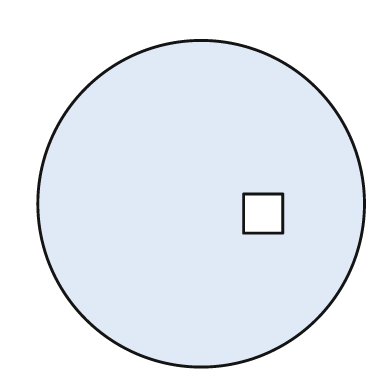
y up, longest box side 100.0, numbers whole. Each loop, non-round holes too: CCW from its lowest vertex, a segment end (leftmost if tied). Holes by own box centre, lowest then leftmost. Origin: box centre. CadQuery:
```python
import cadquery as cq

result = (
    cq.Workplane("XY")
    .moveTo(0.0, 0.0)
    .circle(50.0)
    .moveTo(13.0, -9.0)
    .lineTo(25.0, -9.0)
    .lineTo(25.0, 3.0)
    .lineTo(13.0, 3.0)
    .close()
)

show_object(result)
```